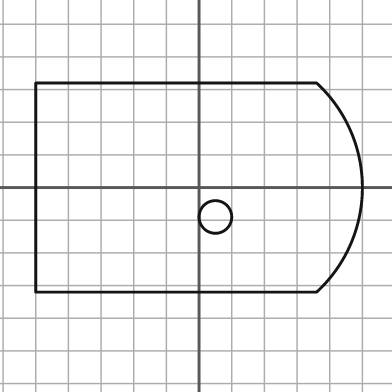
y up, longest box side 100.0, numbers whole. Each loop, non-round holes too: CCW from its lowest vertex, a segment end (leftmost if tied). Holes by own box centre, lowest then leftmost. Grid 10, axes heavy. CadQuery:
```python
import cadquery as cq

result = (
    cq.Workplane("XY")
    .moveTo(-50.0, -32.0)
    .lineTo(36.0, -32.0)
    .threePointArc((50.0, 0.0), (36.0, 32.0))
    .lineTo(-50.0, 32.0)
    .close()
    .moveTo(5.0, -9.0)
    .circle(5.0)
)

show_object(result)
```